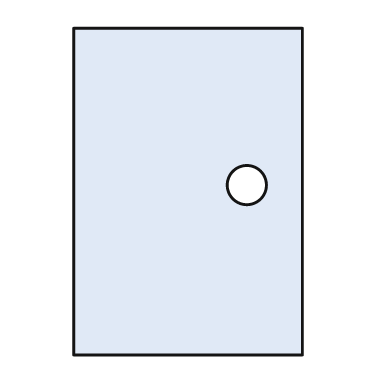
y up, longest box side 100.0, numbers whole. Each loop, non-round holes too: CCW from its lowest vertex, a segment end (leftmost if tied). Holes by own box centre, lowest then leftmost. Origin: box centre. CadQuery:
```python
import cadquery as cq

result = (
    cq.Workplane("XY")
    .moveTo(-35.0, -50.0)
    .lineTo(35.0, -50.0)
    .lineTo(35.0, 50.0)
    .lineTo(-35.0, 50.0)
    .close()
    .moveTo(18.0, 2.0)
    .circle(6.0)
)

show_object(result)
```